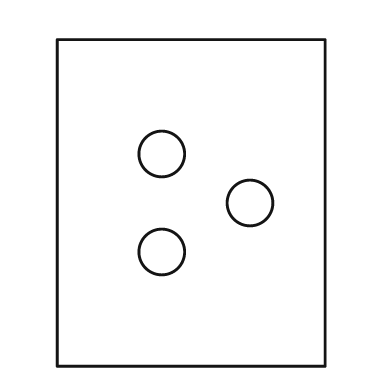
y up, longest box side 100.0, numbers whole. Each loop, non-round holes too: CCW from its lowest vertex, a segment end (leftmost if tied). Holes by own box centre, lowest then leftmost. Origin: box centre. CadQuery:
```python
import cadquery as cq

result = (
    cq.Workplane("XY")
    .moveTo(-41.0, -50.0)
    .lineTo(41.0, -50.0)
    .lineTo(41.0, 50.0)
    .lineTo(-41.0, 50.0)
    .close()
    .moveTo(-9.0, -15.0)
    .circle(7.0)
    .moveTo(18.0, 0.0)
    .circle(7.0)
    .moveTo(-9.0, 15.0)
    .circle(7.0)
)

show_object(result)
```